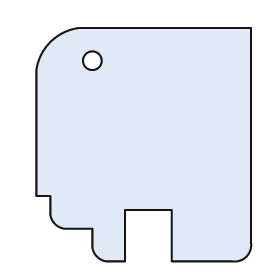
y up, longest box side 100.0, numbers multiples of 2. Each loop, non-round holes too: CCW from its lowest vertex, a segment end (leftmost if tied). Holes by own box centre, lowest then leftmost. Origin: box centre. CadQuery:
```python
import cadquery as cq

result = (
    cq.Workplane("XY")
    .moveTo(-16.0, -50.0)
    .lineTo(-8.0, -50.0)
    .lineTo(-8.0, -28.0)
    .lineTo(12.0, -28.0)
    .lineTo(12.0, -50.0)
    .lineTo(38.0, -50.0)
    .threePointArc((44.0, -48.0), (46.0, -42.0))
    .lineTo(46.0, 50.0)
    .lineTo(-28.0, 50.0)
    .threePointArc((-40.0, 44.0), (-46.0, 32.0))
    .lineTo(-46.0, -22.0)
    .lineTo(-40.0, -22.0)
    .lineTo(-40.0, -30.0)
    .threePointArc((-38.0, -34.0), (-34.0, -36.0))
    .lineTo(-22.0, -36.0)
    .lineTo(-22.0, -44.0)
    .threePointArc((-20.0, -48.0), (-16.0, -50.0))
    .close()
    .moveTo(-22.0, 36.0)
    .circle(4.0)
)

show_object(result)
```